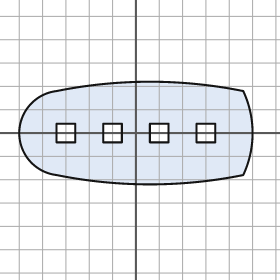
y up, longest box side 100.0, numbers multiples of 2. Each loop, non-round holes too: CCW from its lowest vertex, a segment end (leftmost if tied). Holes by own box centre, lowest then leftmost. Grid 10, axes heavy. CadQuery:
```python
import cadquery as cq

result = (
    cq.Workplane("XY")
    .moveTo(-34.0, -18.0)
    .threePointArc((6.0, -22.0), (46.0, -18.0))
    .threePointArc((50.0, 0.0), (46.0, 18.0))
    .threePointArc((6.0, 22.0), (-34.0, 18.0))
    .threePointArc((-50.0, 0.0), (-34.0, -18.0))
    .close()
    .moveTo(-34.0, -4.0)
    .lineTo(-26.0, -4.0)
    .lineTo(-26.0, 4.0)
    .lineTo(-34.0, 4.0)
    .close()
    .moveTo(-14.0, -4.0)
    .lineTo(-6.0, -4.0)
    .lineTo(-6.0, 4.0)
    .lineTo(-14.0, 4.0)
    .close()
    .moveTo(6.0, -4.0)
    .lineTo(14.0, -4.0)
    .lineTo(14.0, 4.0)
    .lineTo(6.0, 4.0)
    .close()
    .moveTo(26.0, -4.0)
    .lineTo(34.0, -4.0)
    .lineTo(34.0, 4.0)
    .lineTo(26.0, 4.0)
    .close()
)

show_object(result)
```